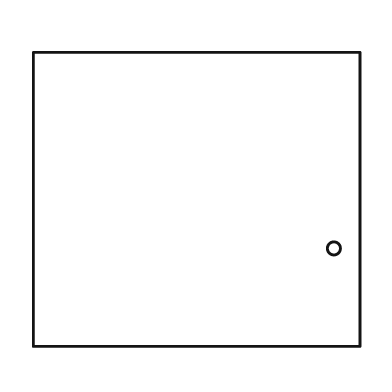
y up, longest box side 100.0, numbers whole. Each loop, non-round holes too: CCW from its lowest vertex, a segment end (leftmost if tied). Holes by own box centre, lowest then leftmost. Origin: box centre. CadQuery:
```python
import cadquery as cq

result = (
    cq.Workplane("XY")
    .moveTo(-50.0, -45.0)
    .lineTo(50.0, -45.0)
    .lineTo(50.0, 45.0)
    .lineTo(-50.0, 45.0)
    .close()
    .moveTo(42.0, -15.0)
    .circle(2.0)
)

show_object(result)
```